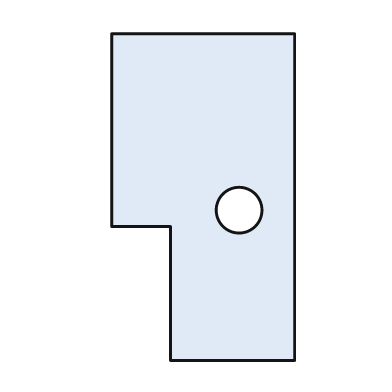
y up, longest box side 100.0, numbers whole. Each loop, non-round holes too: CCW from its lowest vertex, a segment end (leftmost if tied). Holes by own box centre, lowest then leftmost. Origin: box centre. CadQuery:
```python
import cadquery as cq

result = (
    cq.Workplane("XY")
    .moveTo(-10.0, -50.0)
    .lineTo(28.0, -50.0)
    .lineTo(28.0, 50.0)
    .lineTo(-28.0, 50.0)
    .lineTo(-28.0, -9.0)
    .lineTo(-10.0, -9.0)
    .close()
    .moveTo(11.0, -4.0)
    .circle(7.0)
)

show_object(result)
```